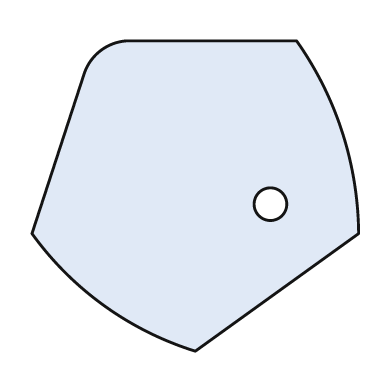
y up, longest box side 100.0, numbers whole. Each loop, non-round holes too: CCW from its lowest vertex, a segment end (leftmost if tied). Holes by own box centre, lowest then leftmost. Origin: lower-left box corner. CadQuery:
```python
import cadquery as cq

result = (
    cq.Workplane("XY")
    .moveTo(50.0, 0.0)
    .lineTo(100.0, 36.0)
    .threePointArc((95.0, 67.0), (81.0, 95.0))
    .lineTo(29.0, 95.0)
    .threePointArc((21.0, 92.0), (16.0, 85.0))
    .lineTo(0.0, 36.0)
    .threePointArc((22.0, 14.0), (50.0, 0.0))
    .close()
    .moveTo(73.0, 45.0)
    .circle(5.0)
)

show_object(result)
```